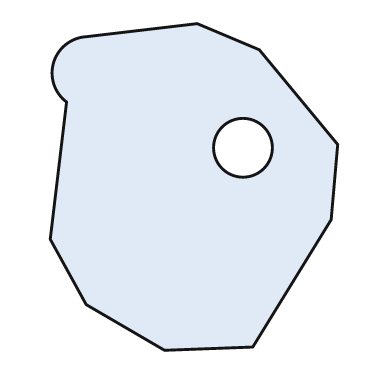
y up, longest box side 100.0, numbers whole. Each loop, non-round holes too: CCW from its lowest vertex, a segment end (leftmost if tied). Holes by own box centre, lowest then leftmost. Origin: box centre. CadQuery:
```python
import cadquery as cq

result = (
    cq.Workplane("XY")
    .moveTo(-9.0, -50.0)
    .lineTo(18.0, -49.0)
    .lineTo(42.0, -10.0)
    .lineTo(44.0, 13.0)
    .lineTo(20.0, 42.0)
    .lineTo(1.0, 50.0)
    .lineTo(-33.0, 46.0)
    .threePointArc((-43.0, 38.0), (-39.0, 26.0))
    .lineTo(-44.0, -16.0)
    .lineTo(-33.0, -36.0)
    .close()
    .moveTo(15.0, 12.0)
    .circle(9.0)
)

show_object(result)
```